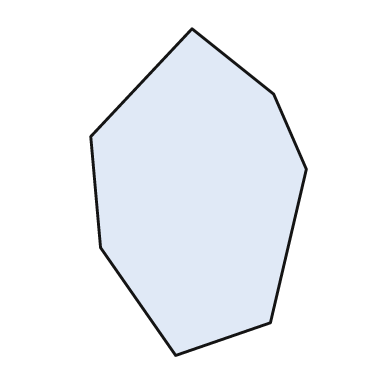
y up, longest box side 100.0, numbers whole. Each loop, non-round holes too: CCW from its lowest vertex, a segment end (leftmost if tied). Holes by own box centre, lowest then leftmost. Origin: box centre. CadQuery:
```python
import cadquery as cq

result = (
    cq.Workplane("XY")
    .moveTo(-7.0, -50.0)
    .lineTo(22.0, -40.0)
    .lineTo(33.0, 7.0)
    .lineTo(23.0, 30.0)
    .lineTo(-2.0, 50.0)
    .lineTo(-33.0, 17.0)
    .lineTo(-30.0, -17.0)
    .close()
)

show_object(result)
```